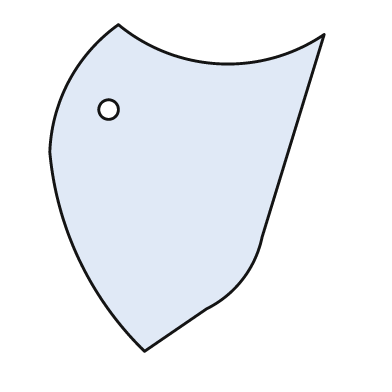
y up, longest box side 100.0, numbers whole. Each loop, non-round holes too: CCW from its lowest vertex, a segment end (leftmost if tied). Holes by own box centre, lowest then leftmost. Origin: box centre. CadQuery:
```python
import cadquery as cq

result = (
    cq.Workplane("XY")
    .moveTo(-13.0, -50.0)
    .lineTo(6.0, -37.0)
    .threePointArc((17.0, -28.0), (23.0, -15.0))
    .lineTo(42.0, 47.0)
    .threePointArc((10.0, 38.0), (-21.0, 50.0))
    .threePointArc((-36.0, 33.0), (-42.0, 11.0))
    .threePointArc((-33.0, -22.0), (-13.0, -50.0))
    .close()
    .moveTo(-24.0, 24.0)
    .circle(3.0)
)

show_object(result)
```